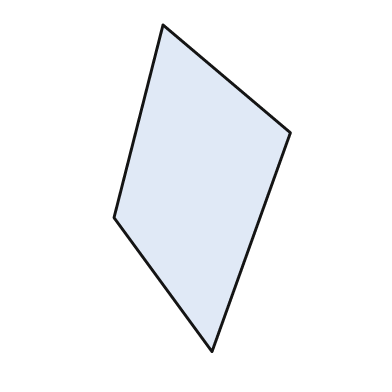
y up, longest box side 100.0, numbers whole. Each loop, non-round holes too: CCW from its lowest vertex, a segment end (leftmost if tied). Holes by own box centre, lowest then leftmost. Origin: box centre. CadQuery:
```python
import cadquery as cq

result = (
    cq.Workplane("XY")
    .moveTo(3.0, -50.0)
    .lineTo(27.0, 17.0)
    .lineTo(-12.0, 50.0)
    .lineTo(-27.0, -9.0)
    .close()
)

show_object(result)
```